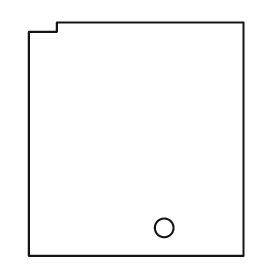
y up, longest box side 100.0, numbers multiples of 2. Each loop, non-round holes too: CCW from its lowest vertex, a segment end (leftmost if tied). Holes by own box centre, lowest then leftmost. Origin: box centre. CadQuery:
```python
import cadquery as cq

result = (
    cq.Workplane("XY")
    .moveTo(-46.0, -50.0)
    .lineTo(46.0, -50.0)
    .lineTo(46.0, 50.0)
    .lineTo(-34.0, 50.0)
    .lineTo(-34.0, 46.0)
    .lineTo(-46.0, 46.0)
    .close()
    .moveTo(12.0, -38.0)
    .circle(4.0)
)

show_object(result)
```